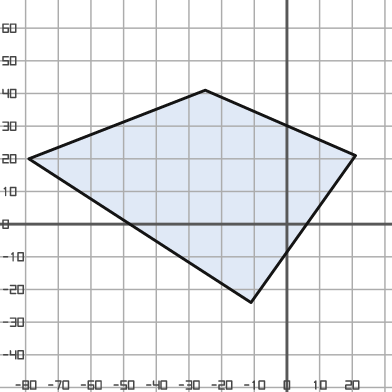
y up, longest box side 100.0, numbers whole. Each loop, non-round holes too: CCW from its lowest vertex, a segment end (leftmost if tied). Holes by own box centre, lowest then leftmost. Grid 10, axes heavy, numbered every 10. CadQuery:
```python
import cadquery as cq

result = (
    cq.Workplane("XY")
    .moveTo(-11.0, -24.0)
    .lineTo(21.0, 21.0)
    .lineTo(-25.0, 41.0)
    .lineTo(-79.0, 20.0)
    .close()
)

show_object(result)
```